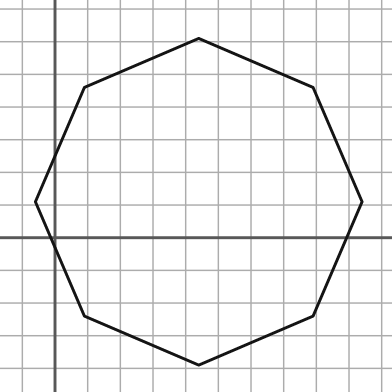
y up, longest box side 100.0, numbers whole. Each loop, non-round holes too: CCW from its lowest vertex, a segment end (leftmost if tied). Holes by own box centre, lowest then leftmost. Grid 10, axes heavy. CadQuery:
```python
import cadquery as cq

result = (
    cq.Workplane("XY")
    .moveTo(44.0, -39.0)
    .lineTo(79.0, -24.0)
    .lineTo(94.0, 11.0)
    .lineTo(79.0, 46.0)
    .lineTo(44.0, 61.0)
    .lineTo(9.0, 46.0)
    .lineTo(-6.0, 11.0)
    .lineTo(9.0, -24.0)
    .close()
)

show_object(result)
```